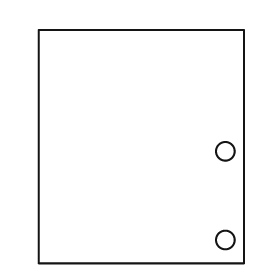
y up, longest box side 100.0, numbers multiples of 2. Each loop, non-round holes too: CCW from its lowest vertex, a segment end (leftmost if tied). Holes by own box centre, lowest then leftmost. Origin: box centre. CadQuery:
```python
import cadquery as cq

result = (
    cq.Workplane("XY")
    .moveTo(-44.0, -50.0)
    .lineTo(44.0, -50.0)
    .lineTo(44.0, 50.0)
    .lineTo(-44.0, 50.0)
    .close()
    .moveTo(36.0, -40.0)
    .circle(4.0)
    .moveTo(36.0, -2.0)
    .circle(4.0)
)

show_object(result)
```